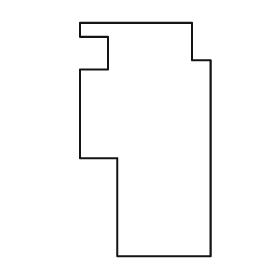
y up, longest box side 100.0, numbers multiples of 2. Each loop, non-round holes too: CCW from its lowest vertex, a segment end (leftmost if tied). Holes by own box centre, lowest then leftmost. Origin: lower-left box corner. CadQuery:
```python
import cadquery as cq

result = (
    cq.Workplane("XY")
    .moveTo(16.0, 0.0)
    .lineTo(56.0, 0.0)
    .lineTo(56.0, 84.0)
    .lineTo(48.0, 84.0)
    .lineTo(48.0, 100.0)
    .lineTo(0.0, 100.0)
    .lineTo(0.0, 94.0)
    .lineTo(12.0, 94.0)
    .lineTo(12.0, 80.0)
    .lineTo(0.0, 80.0)
    .lineTo(0.0, 42.0)
    .lineTo(16.0, 42.0)
    .close()
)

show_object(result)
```